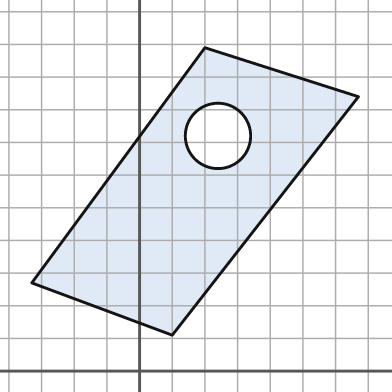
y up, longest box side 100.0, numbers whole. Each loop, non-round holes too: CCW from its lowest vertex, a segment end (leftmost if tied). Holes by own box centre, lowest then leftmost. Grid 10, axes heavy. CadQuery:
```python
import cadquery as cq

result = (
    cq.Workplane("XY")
    .moveTo(10.0, 11.0)
    .lineTo(67.0, 84.0)
    .lineTo(20.0, 99.0)
    .lineTo(-33.0, 27.0)
    .close()
    .moveTo(24.0, 72.0)
    .circle(10.0)
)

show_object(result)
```